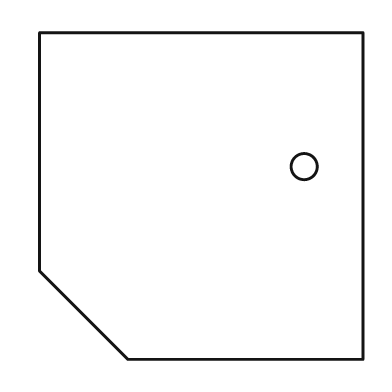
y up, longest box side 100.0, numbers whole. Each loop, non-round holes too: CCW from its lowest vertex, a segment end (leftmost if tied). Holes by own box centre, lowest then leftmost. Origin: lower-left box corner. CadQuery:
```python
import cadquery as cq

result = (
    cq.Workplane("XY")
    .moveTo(27.0, 0.0)
    .lineTo(99.0, 0.0)
    .lineTo(99.0, 100.0)
    .lineTo(0.0, 100.0)
    .lineTo(0.0, 27.0)
    .close()
    .moveTo(81.0, 59.0)
    .circle(4.0)
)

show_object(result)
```